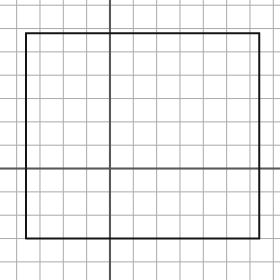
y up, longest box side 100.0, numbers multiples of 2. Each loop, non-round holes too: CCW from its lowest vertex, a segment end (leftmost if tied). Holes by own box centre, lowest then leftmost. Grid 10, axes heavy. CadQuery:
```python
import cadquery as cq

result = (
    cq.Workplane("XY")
    .moveTo(-36.0, -30.0)
    .lineTo(64.0, -30.0)
    .lineTo(64.0, 58.0)
    .lineTo(-36.0, 58.0)
    .close()
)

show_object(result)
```